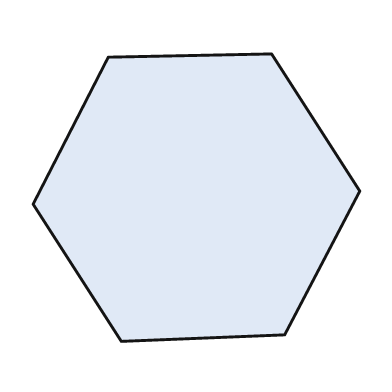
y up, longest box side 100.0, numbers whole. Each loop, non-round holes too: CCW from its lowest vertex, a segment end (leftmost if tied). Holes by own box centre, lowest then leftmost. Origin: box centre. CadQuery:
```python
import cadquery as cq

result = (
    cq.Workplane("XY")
    .moveTo(-23.0, -44.0)
    .lineTo(27.0, -42.0)
    .lineTo(50.0, 2.0)
    .lineTo(23.0, 44.0)
    .lineTo(-27.0, 43.0)
    .lineTo(-50.0, -2.0)
    .close()
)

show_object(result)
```